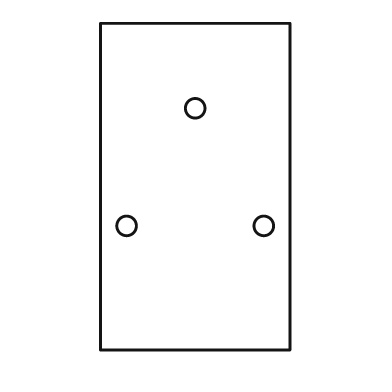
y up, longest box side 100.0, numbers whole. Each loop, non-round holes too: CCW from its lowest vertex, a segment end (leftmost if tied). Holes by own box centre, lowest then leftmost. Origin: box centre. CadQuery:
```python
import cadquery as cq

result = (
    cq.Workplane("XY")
    .moveTo(-29.0, -50.0)
    .lineTo(29.0, -50.0)
    .lineTo(29.0, 50.0)
    .lineTo(-29.0, 50.0)
    .close()
    .moveTo(-21.0, -12.0)
    .circle(3.0)
    .moveTo(21.0, -12.0)
    .circle(3.0)
    .moveTo(0.0, 24.0)
    .circle(3.0)
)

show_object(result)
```